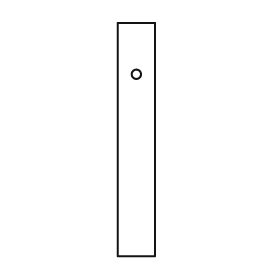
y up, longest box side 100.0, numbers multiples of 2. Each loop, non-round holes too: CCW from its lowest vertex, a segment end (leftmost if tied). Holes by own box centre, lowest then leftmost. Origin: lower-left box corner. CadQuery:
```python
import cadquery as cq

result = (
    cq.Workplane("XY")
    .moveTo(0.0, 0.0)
    .lineTo(16.0, 0.0)
    .lineTo(16.0, 100.0)
    .lineTo(0.0, 100.0)
    .close()
    .moveTo(8.0, 78.0)
    .circle(2.0)
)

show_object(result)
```